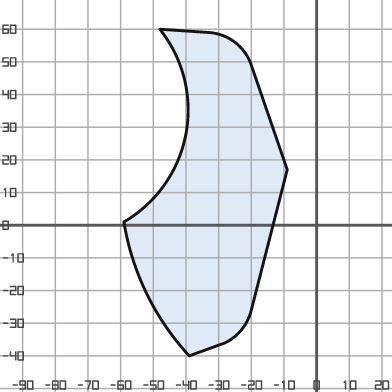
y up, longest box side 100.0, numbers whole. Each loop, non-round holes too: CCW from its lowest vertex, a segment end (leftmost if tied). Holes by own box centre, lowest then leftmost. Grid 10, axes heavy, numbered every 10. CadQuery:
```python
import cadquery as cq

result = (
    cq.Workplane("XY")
    .moveTo(-39.0, -40.0)
    .lineTo(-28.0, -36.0)
    .threePointArc((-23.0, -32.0), (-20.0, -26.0))
    .lineTo(-9.0, 17.0)
    .lineTo(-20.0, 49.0)
    .threePointArc((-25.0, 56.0), (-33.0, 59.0))
    .lineTo(-48.0, 60.0)
    .threePointArc((-40.0, 28.0), (-59.0, 1.0))
    .threePointArc((-52.0, -21.0), (-39.0, -40.0))
    .close()
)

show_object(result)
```